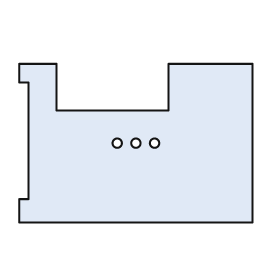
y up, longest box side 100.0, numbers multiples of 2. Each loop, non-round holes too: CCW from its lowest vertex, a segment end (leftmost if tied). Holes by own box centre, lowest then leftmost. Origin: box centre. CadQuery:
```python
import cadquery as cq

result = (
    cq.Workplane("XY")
    .moveTo(-50.0, -34.0)
    .lineTo(50.0, -34.0)
    .lineTo(50.0, 34.0)
    .lineTo(14.0, 34.0)
    .lineTo(14.0, 14.0)
    .lineTo(-34.0, 14.0)
    .lineTo(-34.0, 34.0)
    .lineTo(-50.0, 34.0)
    .lineTo(-50.0, 26.0)
    .lineTo(-46.0, 26.0)
    .lineTo(-46.0, -24.0)
    .lineTo(-50.0, -24.0)
    .close()
    .moveTo(-8.0, 0.0)
    .circle(2.0)
    .moveTo(0.0, 0.0)
    .circle(2.0)
    .moveTo(8.0, 0.0)
    .circle(2.0)
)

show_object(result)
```